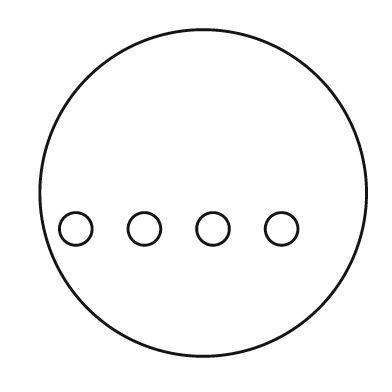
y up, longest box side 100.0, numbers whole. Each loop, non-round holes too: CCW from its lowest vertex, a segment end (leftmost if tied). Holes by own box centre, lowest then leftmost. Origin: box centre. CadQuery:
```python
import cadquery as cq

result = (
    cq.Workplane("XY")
    .moveTo(0.0, 0.0)
    .circle(50.0)
    .moveTo(-39.0, -11.0)
    .circle(5.0)
    .moveTo(-18.0, -11.0)
    .circle(5.0)
    .moveTo(3.0, -11.0)
    .circle(5.0)
    .moveTo(24.0, -11.0)
    .circle(5.0)
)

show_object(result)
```